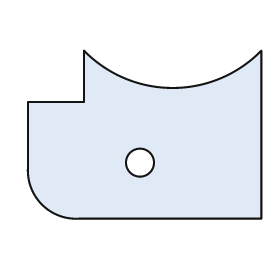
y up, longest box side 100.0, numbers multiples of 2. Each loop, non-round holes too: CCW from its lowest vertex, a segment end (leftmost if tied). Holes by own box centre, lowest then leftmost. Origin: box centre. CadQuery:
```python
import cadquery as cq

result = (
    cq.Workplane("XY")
    .moveTo(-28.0, -36.0)
    .lineTo(50.0, -36.0)
    .lineTo(50.0, 36.0)
    .threePointArc((12.0, 20.0), (-26.0, 36.0))
    .lineTo(-26.0, 14.0)
    .lineTo(-50.0, 14.0)
    .lineTo(-50.0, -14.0)
    .threePointArc((-44.0, -30.0), (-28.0, -36.0))
    .close()
    .moveTo(-2.0, -12.0)
    .circle(6.0)
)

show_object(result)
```